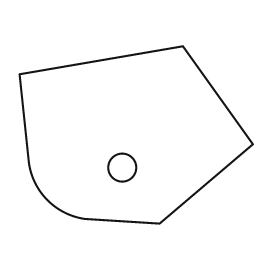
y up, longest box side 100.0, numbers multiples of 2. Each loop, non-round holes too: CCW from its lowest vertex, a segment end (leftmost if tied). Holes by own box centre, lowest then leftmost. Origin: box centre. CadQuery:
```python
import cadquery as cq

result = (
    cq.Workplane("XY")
    .moveTo(10.0, -38.0)
    .lineTo(50.0, -4.0)
    .lineTo(20.0, 38.0)
    .lineTo(-50.0, 26.0)
    .lineTo(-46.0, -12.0)
    .threePointArc((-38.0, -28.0), (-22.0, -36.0))
    .close()
    .moveTo(-6.0, -14.0)
    .circle(6.0)
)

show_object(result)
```